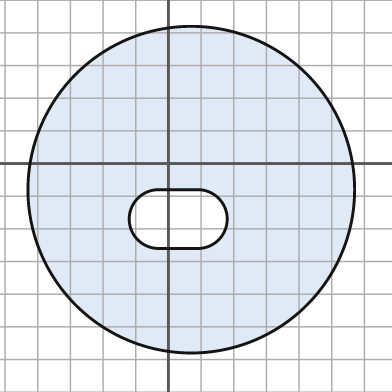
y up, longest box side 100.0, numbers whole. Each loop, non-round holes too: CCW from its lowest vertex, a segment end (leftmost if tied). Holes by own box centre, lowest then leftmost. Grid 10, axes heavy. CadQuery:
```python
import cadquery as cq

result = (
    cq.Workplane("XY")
    .moveTo(7.0, -8.0)
    .circle(50.0)
    .moveTo(-3.0, -26.0)
    .lineTo(9.0, -26.0)
    .threePointArc((18.0, -17.0), (9.0, -8.0))
    .lineTo(-3.0, -8.0)
    .threePointArc((-12.0, -17.0), (-3.0, -26.0))
    .close()
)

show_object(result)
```